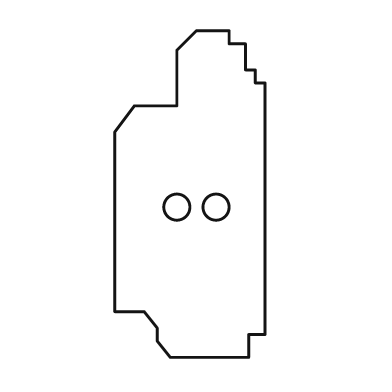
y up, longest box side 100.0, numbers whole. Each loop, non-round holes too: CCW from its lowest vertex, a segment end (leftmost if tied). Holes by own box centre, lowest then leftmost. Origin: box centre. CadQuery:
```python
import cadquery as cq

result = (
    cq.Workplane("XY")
    .moveTo(-6.0, -50.0)
    .lineTo(18.0, -50.0)
    .lineTo(18.0, -43.0)
    .lineTo(23.0, -43.0)
    .lineTo(23.0, 34.0)
    .lineTo(20.0, 34.0)
    .lineTo(20.0, 38.0)
    .lineTo(17.0, 38.0)
    .lineTo(17.0, 46.0)
    .lineTo(12.0, 46.0)
    .lineTo(12.0, 50.0)
    .lineTo(2.0, 50.0)
    .lineTo(-4.0, 44.0)
    .lineTo(-4.0, 27.0)
    .lineTo(-17.0, 27.0)
    .lineTo(-23.0, 19.0)
    .lineTo(-23.0, -36.0)
    .lineTo(-14.0, -36.0)
    .lineTo(-10.0, -41.0)
    .lineTo(-10.0, -45.0)
    .close()
    .moveTo(-4.0, -4.0)
    .circle(4.0)
    .moveTo(8.0, -4.0)
    .circle(4.0)
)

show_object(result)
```